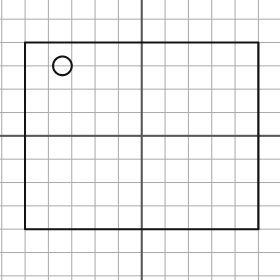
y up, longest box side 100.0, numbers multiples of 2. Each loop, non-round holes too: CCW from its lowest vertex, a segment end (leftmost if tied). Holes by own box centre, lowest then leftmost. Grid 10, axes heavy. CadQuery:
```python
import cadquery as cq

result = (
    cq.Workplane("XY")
    .moveTo(-50.0, -40.0)
    .lineTo(50.0, -40.0)
    .lineTo(50.0, 40.0)
    .lineTo(-50.0, 40.0)
    .close()
    .moveTo(-34.0, 30.0)
    .circle(4.0)
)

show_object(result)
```